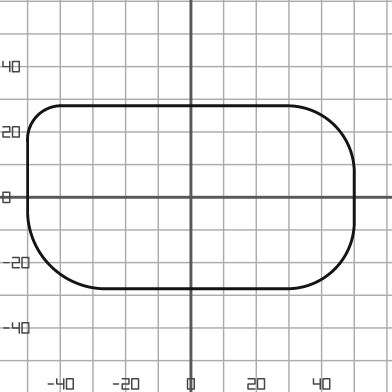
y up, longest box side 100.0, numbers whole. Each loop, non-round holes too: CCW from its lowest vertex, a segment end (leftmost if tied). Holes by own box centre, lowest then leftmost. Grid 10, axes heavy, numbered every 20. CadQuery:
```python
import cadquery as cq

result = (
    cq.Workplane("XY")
    .moveTo(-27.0, -28.0)
    .lineTo(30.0, -28.0)
    .threePointArc((44.0, -22.0), (50.0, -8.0))
    .lineTo(50.0, 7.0)
    .threePointArc((44.0, 22.0), (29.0, 28.0))
    .lineTo(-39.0, 28.0)
    .threePointArc((-47.0, 25.0), (-50.0, 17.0))
    .lineTo(-50.0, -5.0)
    .threePointArc((-43.0, -21.0), (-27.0, -28.0))
    .close()
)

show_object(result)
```